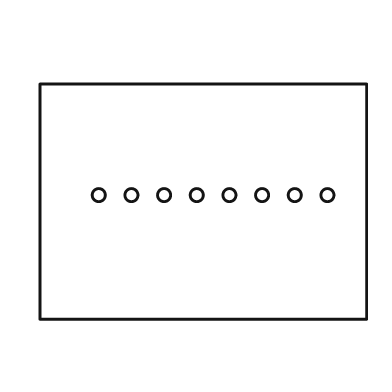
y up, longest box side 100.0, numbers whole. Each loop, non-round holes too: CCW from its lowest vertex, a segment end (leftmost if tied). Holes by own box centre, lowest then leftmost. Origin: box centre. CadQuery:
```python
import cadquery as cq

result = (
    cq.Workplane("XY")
    .moveTo(-50.0, -36.0)
    .lineTo(50.0, -36.0)
    .lineTo(50.0, 36.0)
    .lineTo(-50.0, 36.0)
    .close()
    .moveTo(-32.0, 2.0)
    .circle(2.0)
    .moveTo(-22.0, 2.0)
    .circle(2.0)
    .moveTo(-12.0, 2.0)
    .circle(2.0)
    .moveTo(-2.0, 2.0)
    .circle(2.0)
    .moveTo(8.0, 2.0)
    .circle(2.0)
    .moveTo(18.0, 2.0)
    .circle(2.0)
    .moveTo(28.0, 2.0)
    .circle(2.0)
    .moveTo(38.0, 2.0)
    .circle(2.0)
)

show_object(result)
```